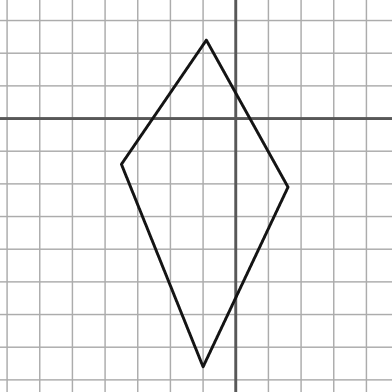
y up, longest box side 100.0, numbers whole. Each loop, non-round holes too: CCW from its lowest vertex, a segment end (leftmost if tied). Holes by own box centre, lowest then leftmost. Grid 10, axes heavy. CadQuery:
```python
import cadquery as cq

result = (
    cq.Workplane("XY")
    .moveTo(-10.0, -76.0)
    .lineTo(16.0, -21.0)
    .lineTo(-9.0, 24.0)
    .lineTo(-35.0, -14.0)
    .close()
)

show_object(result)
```